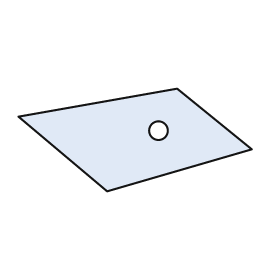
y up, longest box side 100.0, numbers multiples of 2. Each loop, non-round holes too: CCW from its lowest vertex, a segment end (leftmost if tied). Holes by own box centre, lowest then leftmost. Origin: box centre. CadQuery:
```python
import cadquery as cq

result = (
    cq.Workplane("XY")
    .moveTo(-12.0, -22.0)
    .lineTo(50.0, -4.0)
    .lineTo(18.0, 22.0)
    .lineTo(-50.0, 10.0)
    .close()
    .moveTo(10.0, 4.0)
    .circle(4.0)
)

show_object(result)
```